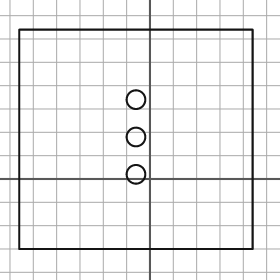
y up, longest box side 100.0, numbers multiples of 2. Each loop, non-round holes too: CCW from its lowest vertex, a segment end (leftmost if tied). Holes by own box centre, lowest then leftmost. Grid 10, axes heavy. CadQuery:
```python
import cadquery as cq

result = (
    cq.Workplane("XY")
    .moveTo(-56.0, -30.0)
    .lineTo(44.0, -30.0)
    .lineTo(44.0, 64.0)
    .lineTo(-56.0, 64.0)
    .close()
    .moveTo(-6.0, 2.0)
    .circle(4.0)
    .moveTo(-6.0, 18.0)
    .circle(4.0)
    .moveTo(-6.0, 34.0)
    .circle(4.0)
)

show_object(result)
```